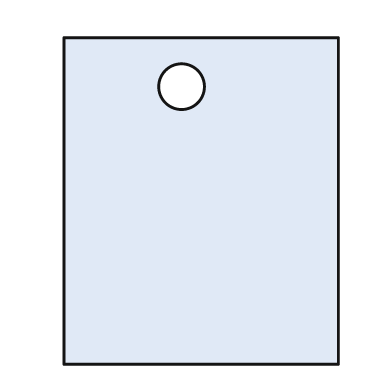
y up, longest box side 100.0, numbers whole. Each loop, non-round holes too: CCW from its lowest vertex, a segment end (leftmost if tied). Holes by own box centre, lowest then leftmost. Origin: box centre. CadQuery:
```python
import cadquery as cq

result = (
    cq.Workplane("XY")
    .moveTo(-42.0, -50.0)
    .lineTo(42.0, -50.0)
    .lineTo(42.0, 50.0)
    .lineTo(-42.0, 50.0)
    .close()
    .moveTo(-6.0, 35.0)
    .circle(7.0)
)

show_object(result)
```